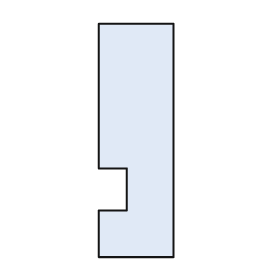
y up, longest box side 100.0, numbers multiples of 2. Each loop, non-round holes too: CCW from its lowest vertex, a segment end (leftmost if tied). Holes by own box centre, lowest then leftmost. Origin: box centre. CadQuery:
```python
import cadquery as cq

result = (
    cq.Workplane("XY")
    .moveTo(-16.0, -50.0)
    .lineTo(16.0, -50.0)
    .lineTo(16.0, 50.0)
    .lineTo(-16.0, 50.0)
    .lineTo(-16.0, -12.0)
    .lineTo(-4.0, -12.0)
    .lineTo(-4.0, -30.0)
    .lineTo(-16.0, -30.0)
    .close()
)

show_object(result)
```